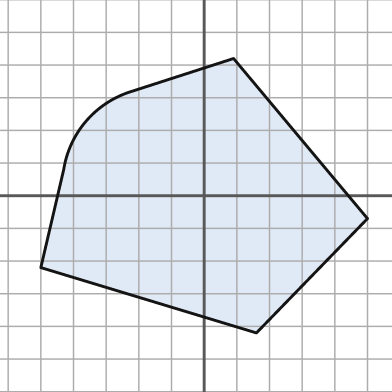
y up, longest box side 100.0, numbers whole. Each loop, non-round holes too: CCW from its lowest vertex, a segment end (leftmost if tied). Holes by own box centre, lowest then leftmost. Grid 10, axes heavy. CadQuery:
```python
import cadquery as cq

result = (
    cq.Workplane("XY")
    .moveTo(16.0, -42.0)
    .lineTo(50.0, -7.0)
    .lineTo(9.0, 42.0)
    .lineTo(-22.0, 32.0)
    .threePointArc((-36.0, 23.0), (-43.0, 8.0))
    .lineTo(-50.0, -22.0)
    .close()
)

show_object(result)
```